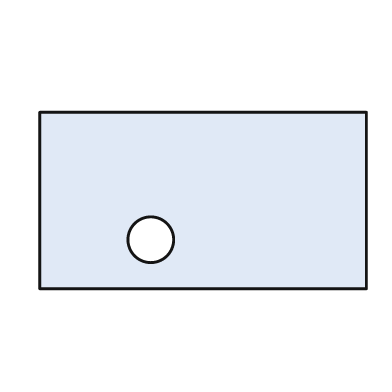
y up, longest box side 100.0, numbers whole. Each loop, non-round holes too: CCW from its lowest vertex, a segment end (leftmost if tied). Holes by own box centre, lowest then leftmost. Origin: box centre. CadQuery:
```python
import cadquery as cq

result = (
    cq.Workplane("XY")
    .moveTo(-50.0, -27.0)
    .lineTo(50.0, -27.0)
    .lineTo(50.0, 27.0)
    .lineTo(-50.0, 27.0)
    .close()
    .moveTo(-16.0, -12.0)
    .circle(7.0)
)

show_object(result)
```